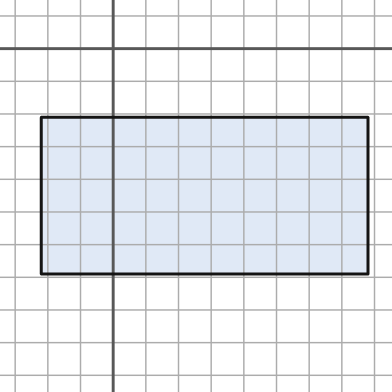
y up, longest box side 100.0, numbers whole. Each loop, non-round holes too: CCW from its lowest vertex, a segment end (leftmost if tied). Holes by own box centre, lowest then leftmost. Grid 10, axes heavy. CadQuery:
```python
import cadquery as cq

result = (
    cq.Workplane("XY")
    .moveTo(-22.0, -69.0)
    .lineTo(78.0, -69.0)
    .lineTo(78.0, -21.0)
    .lineTo(-22.0, -21.0)
    .close()
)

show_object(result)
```